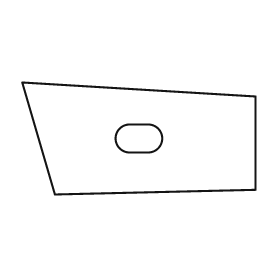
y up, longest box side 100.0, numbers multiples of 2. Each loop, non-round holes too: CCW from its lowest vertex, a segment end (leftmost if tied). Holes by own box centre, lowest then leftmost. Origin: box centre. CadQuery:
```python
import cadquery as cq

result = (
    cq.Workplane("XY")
    .moveTo(-36.0, -24.0)
    .lineTo(50.0, -22.0)
    .lineTo(50.0, 18.0)
    .lineTo(-50.0, 24.0)
    .close()
    .moveTo(-4.0, -6.0)
    .lineTo(4.0, -6.0)
    .threePointArc((10.0, 0.0), (4.0, 6.0))
    .lineTo(-4.0, 6.0)
    .threePointArc((-10.0, 0.0), (-4.0, -6.0))
    .close()
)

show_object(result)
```